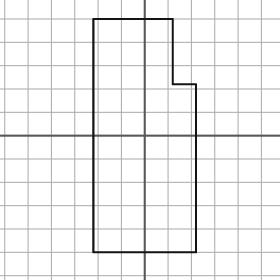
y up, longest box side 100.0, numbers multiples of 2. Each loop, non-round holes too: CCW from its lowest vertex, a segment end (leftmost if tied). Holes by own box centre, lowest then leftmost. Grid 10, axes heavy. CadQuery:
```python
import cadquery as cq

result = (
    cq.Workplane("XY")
    .moveTo(-22.0, -50.0)
    .lineTo(22.0, -50.0)
    .lineTo(22.0, 22.0)
    .lineTo(12.0, 22.0)
    .lineTo(12.0, 50.0)
    .lineTo(-22.0, 50.0)
    .close()
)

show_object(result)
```